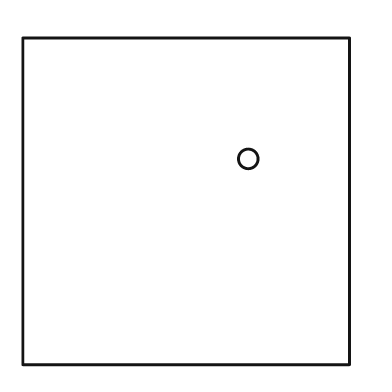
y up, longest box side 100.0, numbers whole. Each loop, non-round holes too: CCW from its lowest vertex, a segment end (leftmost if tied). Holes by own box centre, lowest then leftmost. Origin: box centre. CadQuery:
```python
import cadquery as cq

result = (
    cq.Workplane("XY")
    .moveTo(-50.0, -50.0)
    .lineTo(50.0, -50.0)
    .lineTo(50.0, 50.0)
    .lineTo(-50.0, 50.0)
    .close()
    .moveTo(19.0, 13.0)
    .circle(3.0)
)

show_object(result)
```